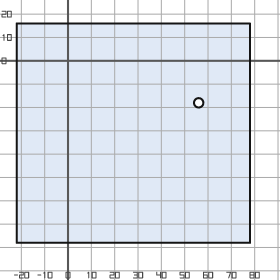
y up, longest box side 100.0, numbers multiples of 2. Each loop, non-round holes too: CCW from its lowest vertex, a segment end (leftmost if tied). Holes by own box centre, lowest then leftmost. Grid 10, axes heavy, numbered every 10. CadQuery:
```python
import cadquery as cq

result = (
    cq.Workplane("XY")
    .moveTo(-22.0, -78.0)
    .lineTo(78.0, -78.0)
    .lineTo(78.0, 16.0)
    .lineTo(-22.0, 16.0)
    .close()
    .moveTo(56.0, -18.0)
    .circle(2.0)
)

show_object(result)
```